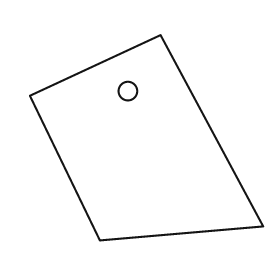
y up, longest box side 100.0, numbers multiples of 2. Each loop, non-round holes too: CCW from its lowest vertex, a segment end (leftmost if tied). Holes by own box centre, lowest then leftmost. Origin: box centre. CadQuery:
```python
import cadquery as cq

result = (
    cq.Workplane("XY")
    .moveTo(-20.0, -44.0)
    .lineTo(50.0, -38.0)
    .lineTo(6.0, 44.0)
    .lineTo(-50.0, 18.0)
    .close()
    .moveTo(-8.0, 20.0)
    .circle(4.0)
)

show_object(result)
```